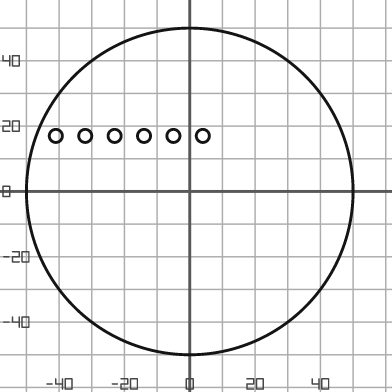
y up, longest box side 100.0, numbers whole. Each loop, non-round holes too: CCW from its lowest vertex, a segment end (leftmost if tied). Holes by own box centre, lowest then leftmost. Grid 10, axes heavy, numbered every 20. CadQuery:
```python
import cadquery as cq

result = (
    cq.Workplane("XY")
    .moveTo(0.0, 0.0)
    .circle(50.0)
    .moveTo(-41.0, 17.0)
    .circle(2.0)
    .moveTo(-32.0, 17.0)
    .circle(2.0)
    .moveTo(-23.0, 17.0)
    .circle(2.0)
    .moveTo(-14.0, 17.0)
    .circle(2.0)
    .moveTo(-5.0, 17.0)
    .circle(2.0)
    .moveTo(4.0, 17.0)
    .circle(2.0)
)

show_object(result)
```